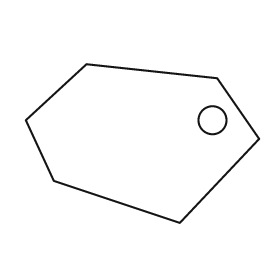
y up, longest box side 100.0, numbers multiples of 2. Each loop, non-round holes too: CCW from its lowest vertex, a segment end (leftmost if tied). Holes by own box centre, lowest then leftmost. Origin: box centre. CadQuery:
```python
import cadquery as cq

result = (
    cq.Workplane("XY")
    .moveTo(16.0, -34.0)
    .lineTo(50.0, 2.0)
    .lineTo(32.0, 28.0)
    .lineTo(-24.0, 34.0)
    .lineTo(-50.0, 10.0)
    .lineTo(-38.0, -16.0)
    .close()
    .moveTo(30.0, 10.0)
    .circle(6.0)
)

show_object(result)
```